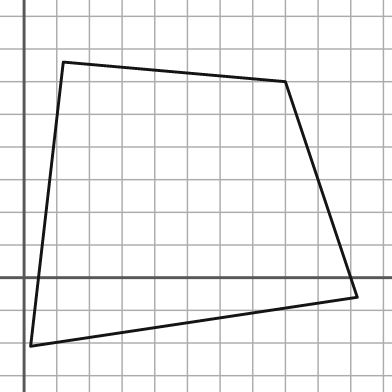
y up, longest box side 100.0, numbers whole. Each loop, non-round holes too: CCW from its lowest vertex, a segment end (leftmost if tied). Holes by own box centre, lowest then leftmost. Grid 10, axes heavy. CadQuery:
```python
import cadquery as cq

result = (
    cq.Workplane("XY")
    .moveTo(2.0, -21.0)
    .lineTo(102.0, -6.0)
    .lineTo(80.0, 60.0)
    .lineTo(12.0, 66.0)
    .close()
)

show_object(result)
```